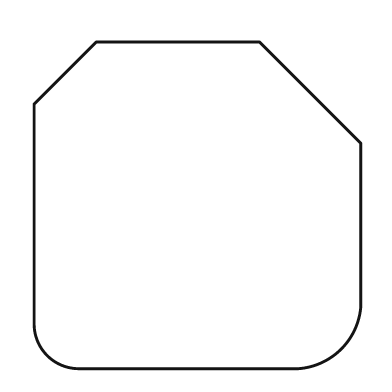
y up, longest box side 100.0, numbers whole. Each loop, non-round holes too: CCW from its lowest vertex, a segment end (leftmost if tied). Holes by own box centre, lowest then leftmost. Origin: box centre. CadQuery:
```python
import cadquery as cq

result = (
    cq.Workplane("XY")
    .moveTo(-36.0, -50.0)
    .lineTo(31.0, -50.0)
    .threePointArc((44.0, -44.0), (50.0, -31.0))
    .lineTo(50.0, 19.0)
    .lineTo(19.0, 50.0)
    .lineTo(-31.0, 50.0)
    .lineTo(-50.0, 31.0)
    .lineTo(-50.0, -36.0)
    .threePointArc((-46.0, -46.0), (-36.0, -50.0))
    .close()
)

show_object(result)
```